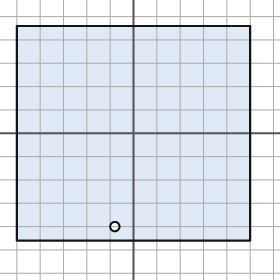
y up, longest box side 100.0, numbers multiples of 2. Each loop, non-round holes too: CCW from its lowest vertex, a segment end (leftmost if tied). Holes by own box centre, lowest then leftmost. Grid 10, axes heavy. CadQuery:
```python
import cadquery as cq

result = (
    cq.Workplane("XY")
    .moveTo(-50.0, -46.0)
    .lineTo(50.0, -46.0)
    .lineTo(50.0, 46.0)
    .lineTo(-50.0, 46.0)
    .close()
    .moveTo(-8.0, -40.0)
    .circle(2.0)
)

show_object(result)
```